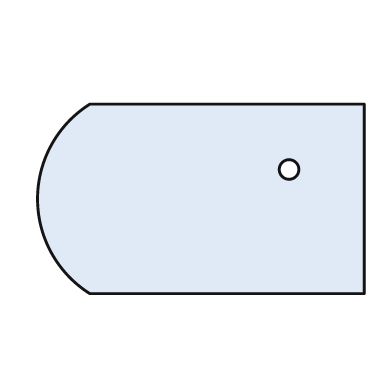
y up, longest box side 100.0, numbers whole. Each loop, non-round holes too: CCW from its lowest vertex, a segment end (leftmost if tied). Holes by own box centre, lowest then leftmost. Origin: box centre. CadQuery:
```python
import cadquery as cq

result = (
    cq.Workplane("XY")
    .moveTo(-34.0, -29.0)
    .lineTo(50.0, -29.0)
    .lineTo(50.0, 29.0)
    .lineTo(-34.0, 29.0)
    .threePointArc((-50.0, 0.0), (-34.0, -29.0))
    .close()
    .moveTo(27.0, 9.0)
    .circle(3.0)
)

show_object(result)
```